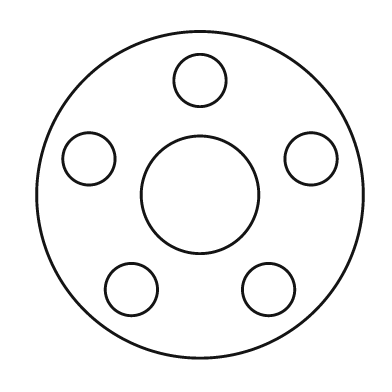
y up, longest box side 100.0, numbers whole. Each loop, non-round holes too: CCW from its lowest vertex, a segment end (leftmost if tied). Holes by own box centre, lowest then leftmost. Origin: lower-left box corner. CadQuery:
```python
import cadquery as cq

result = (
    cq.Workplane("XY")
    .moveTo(50.0, 50.0)
    .circle(50.0)
    .moveTo(29.0, 21.0)
    .circle(8.0)
    .moveTo(71.0, 21.0)
    .circle(8.0)
    .moveTo(50.0, 50.0)
    .circle(18.0)
    .moveTo(16.0, 61.0)
    .circle(8.0)
    .moveTo(84.0, 61.0)
    .circle(8.0)
    .moveTo(50.0, 85.0)
    .circle(8.0)
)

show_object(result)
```